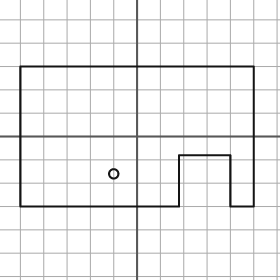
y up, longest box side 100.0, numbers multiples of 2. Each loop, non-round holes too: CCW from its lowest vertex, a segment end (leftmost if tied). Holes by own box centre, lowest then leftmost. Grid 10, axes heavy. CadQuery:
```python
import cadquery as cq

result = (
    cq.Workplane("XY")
    .moveTo(-50.0, -30.0)
    .lineTo(18.0, -30.0)
    .lineTo(18.0, -8.0)
    .lineTo(40.0, -8.0)
    .lineTo(40.0, -30.0)
    .lineTo(50.0, -30.0)
    .lineTo(50.0, 30.0)
    .lineTo(-50.0, 30.0)
    .close()
    .moveTo(-10.0, -16.0)
    .circle(2.0)
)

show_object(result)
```